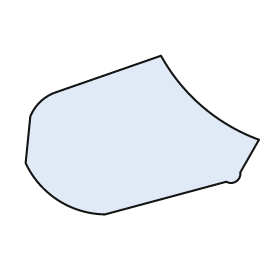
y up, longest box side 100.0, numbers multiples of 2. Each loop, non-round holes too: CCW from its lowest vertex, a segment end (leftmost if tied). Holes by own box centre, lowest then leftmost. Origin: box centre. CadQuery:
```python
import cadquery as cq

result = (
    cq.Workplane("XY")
    .moveTo(-16.0, -34.0)
    .lineTo(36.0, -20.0)
    .threePointArc((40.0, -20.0), (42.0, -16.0))
    .lineTo(50.0, -2.0)
    .threePointArc((26.0, 12.0), (8.0, 34.0))
    .lineTo(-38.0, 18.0)
    .threePointArc((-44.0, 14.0), (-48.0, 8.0))
    .lineTo(-50.0, -12.0)
    .threePointArc((-36.0, -28.0), (-16.0, -34.0))
    .close()
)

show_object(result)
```